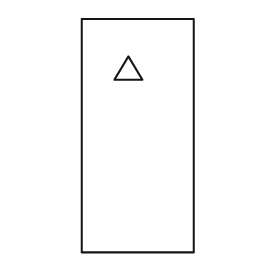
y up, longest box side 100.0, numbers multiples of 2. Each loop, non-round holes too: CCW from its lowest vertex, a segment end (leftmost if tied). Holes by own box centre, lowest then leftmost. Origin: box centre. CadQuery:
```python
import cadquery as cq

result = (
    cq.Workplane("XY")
    .moveTo(-24.0, -50.0)
    .lineTo(24.0, -50.0)
    .lineTo(24.0, 50.0)
    .lineTo(-24.0, 50.0)
    .close()
    .moveTo(-10.0, 24.0)
    .lineTo(2.0, 24.0)
    .lineTo(-4.0, 34.0)
    .close()
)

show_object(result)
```